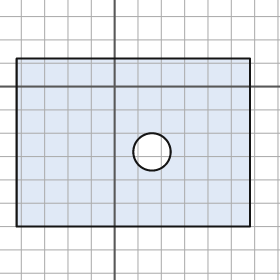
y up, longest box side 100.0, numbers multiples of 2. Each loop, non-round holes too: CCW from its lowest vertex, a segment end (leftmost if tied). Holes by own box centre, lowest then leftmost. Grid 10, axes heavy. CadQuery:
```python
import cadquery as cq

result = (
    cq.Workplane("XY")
    .moveTo(-42.0, -60.0)
    .lineTo(58.0, -60.0)
    .lineTo(58.0, 12.0)
    .lineTo(-42.0, 12.0)
    .close()
    .moveTo(16.0, -28.0)
    .circle(8.0)
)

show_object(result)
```